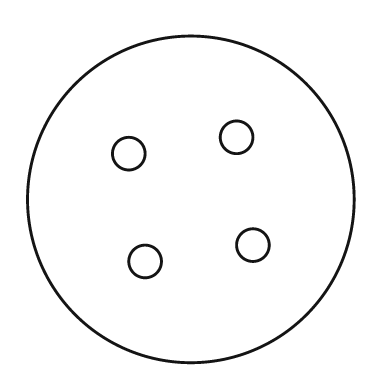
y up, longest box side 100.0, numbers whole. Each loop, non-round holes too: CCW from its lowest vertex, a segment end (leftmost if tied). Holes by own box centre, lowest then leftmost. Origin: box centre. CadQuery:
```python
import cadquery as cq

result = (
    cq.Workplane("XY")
    .moveTo(0.0, 0.0)
    .circle(50.0)
    .moveTo(-14.0, -19.0)
    .circle(5.0)
    .moveTo(19.0, -14.0)
    .circle(5.0)
    .moveTo(-19.0, 14.0)
    .circle(5.0)
    .moveTo(14.0, 19.0)
    .circle(5.0)
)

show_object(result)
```